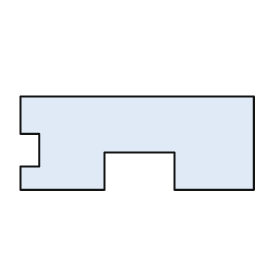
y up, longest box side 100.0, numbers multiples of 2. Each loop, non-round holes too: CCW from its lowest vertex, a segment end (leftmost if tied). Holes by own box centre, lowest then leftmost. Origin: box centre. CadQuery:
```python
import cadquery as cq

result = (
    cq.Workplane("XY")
    .moveTo(-50.0, -20.0)
    .lineTo(-14.0, -20.0)
    .lineTo(-14.0, -4.0)
    .lineTo(16.0, -4.0)
    .lineTo(16.0, -20.0)
    .lineTo(50.0, -20.0)
    .lineTo(50.0, 20.0)
    .lineTo(-50.0, 20.0)
    .lineTo(-50.0, 4.0)
    .lineTo(-42.0, 4.0)
    .lineTo(-42.0, -10.0)
    .lineTo(-50.0, -10.0)
    .close()
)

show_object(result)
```